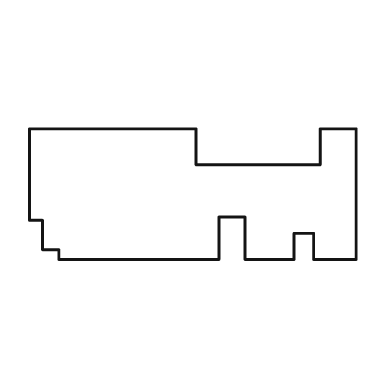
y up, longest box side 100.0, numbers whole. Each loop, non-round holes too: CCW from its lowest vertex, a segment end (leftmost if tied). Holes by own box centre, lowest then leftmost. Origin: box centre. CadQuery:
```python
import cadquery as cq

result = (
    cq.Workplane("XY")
    .moveTo(-41.0, -20.0)
    .lineTo(8.0, -20.0)
    .lineTo(8.0, -7.0)
    .lineTo(16.0, -7.0)
    .lineTo(16.0, -20.0)
    .lineTo(31.0, -20.0)
    .lineTo(31.0, -12.0)
    .lineTo(37.0, -12.0)
    .lineTo(37.0, -20.0)
    .lineTo(50.0, -20.0)
    .lineTo(50.0, 20.0)
    .lineTo(39.0, 20.0)
    .lineTo(39.0, 9.0)
    .lineTo(1.0, 9.0)
    .lineTo(1.0, 20.0)
    .lineTo(-50.0, 20.0)
    .lineTo(-50.0, -8.0)
    .lineTo(-46.0, -8.0)
    .lineTo(-46.0, -17.0)
    .lineTo(-41.0, -17.0)
    .close()
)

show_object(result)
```